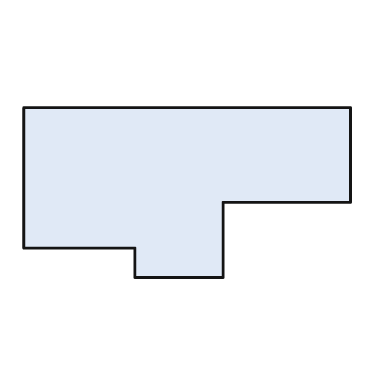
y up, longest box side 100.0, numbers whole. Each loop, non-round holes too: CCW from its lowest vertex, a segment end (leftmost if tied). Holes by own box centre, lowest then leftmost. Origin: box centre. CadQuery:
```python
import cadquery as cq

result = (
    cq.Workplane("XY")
    .moveTo(-16.0, -26.0)
    .lineTo(11.0, -26.0)
    .lineTo(11.0, -3.0)
    .lineTo(50.0, -3.0)
    .lineTo(50.0, 26.0)
    .lineTo(-50.0, 26.0)
    .lineTo(-50.0, -17.0)
    .lineTo(-16.0, -17.0)
    .close()
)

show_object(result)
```